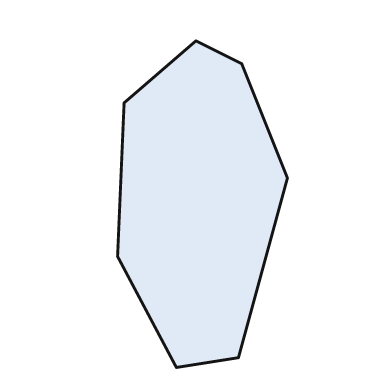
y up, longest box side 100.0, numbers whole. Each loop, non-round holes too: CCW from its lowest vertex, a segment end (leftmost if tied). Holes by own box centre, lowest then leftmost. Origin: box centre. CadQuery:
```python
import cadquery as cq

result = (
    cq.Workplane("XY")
    .moveTo(-8.0, -50.0)
    .lineTo(11.0, -47.0)
    .lineTo(26.0, 8.0)
    .lineTo(12.0, 43.0)
    .lineTo(-2.0, 50.0)
    .lineTo(-24.0, 31.0)
    .lineTo(-26.0, -16.0)
    .close()
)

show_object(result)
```